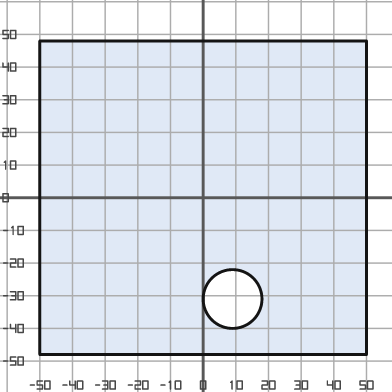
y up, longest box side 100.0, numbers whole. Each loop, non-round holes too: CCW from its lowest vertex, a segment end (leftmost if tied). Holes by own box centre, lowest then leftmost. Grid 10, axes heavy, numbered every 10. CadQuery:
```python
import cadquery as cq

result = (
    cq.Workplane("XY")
    .moveTo(-50.0, -48.0)
    .lineTo(50.0, -48.0)
    .lineTo(50.0, 48.0)
    .lineTo(-50.0, 48.0)
    .close()
    .moveTo(9.0, -31.0)
    .circle(9.0)
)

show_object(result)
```